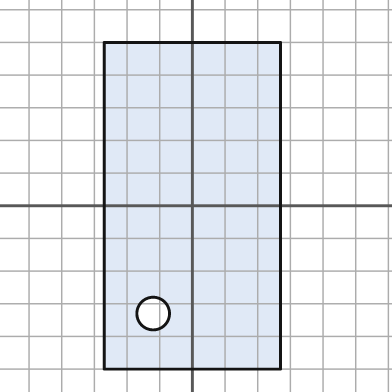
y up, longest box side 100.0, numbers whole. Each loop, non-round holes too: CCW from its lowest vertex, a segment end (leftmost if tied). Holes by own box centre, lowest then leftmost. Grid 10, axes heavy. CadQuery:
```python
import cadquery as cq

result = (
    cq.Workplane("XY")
    .moveTo(-27.0, -50.0)
    .lineTo(27.0, -50.0)
    .lineTo(27.0, 50.0)
    .lineTo(-27.0, 50.0)
    .close()
    .moveTo(-12.0, -33.0)
    .circle(5.0)
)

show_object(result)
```